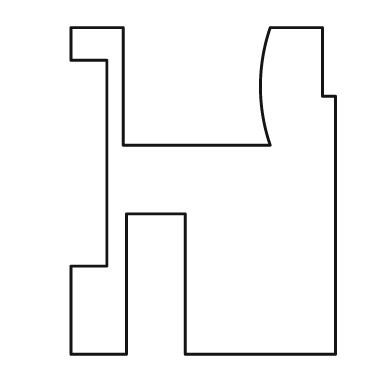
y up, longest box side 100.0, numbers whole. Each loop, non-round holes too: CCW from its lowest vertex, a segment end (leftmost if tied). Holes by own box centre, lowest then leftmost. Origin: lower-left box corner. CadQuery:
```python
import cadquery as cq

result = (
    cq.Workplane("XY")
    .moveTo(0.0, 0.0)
    .lineTo(17.0, 0.0)
    .lineTo(17.0, 43.0)
    .lineTo(35.0, 43.0)
    .lineTo(35.0, 0.0)
    .lineTo(81.0, 0.0)
    .lineTo(81.0, 79.0)
    .lineTo(77.0, 79.0)
    .lineTo(77.0, 100.0)
    .lineTo(61.0, 100.0)
    .threePointArc((58.0, 82.0), (61.0, 64.0))
    .lineTo(16.0, 64.0)
    .lineTo(16.0, 100.0)
    .lineTo(0.0, 100.0)
    .lineTo(0.0, 90.0)
    .lineTo(11.0, 90.0)
    .lineTo(11.0, 27.0)
    .lineTo(0.0, 27.0)
    .close()
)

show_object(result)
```